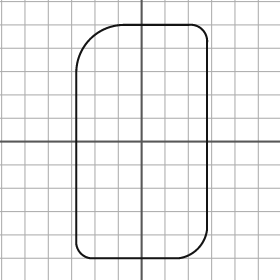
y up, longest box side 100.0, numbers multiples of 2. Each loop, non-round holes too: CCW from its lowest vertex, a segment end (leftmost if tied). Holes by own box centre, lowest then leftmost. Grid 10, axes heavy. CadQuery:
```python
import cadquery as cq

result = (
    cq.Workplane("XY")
    .moveTo(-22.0, -50.0)
    .lineTo(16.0, -50.0)
    .threePointArc((24.0, -46.0), (28.0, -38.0))
    .lineTo(28.0, 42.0)
    .threePointArc((26.0, 48.0), (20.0, 50.0))
    .lineTo(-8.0, 50.0)
    .threePointArc((-22.0, 44.0), (-28.0, 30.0))
    .lineTo(-28.0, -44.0)
    .threePointArc((-26.0, -48.0), (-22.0, -50.0))
    .close()
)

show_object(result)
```